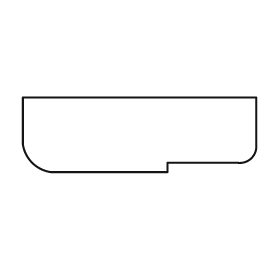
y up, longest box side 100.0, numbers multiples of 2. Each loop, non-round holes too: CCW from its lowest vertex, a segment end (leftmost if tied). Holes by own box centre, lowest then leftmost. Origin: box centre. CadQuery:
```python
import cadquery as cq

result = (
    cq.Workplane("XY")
    .moveTo(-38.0, -16.0)
    .lineTo(12.0, -16.0)
    .lineTo(12.0, -12.0)
    .lineTo(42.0, -12.0)
    .threePointArc((48.0, -10.0), (50.0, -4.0))
    .lineTo(50.0, 16.0)
    .lineTo(-50.0, 16.0)
    .lineTo(-50.0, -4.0)
    .threePointArc((-46.0, -12.0), (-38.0, -16.0))
    .close()
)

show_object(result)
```